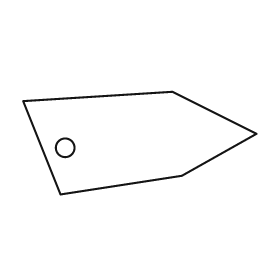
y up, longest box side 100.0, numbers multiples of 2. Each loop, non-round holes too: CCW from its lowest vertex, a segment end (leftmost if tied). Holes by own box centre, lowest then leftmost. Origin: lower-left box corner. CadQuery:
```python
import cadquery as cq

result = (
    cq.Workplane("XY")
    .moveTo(16.0, 0.0)
    .lineTo(68.0, 8.0)
    .lineTo(100.0, 26.0)
    .lineTo(64.0, 44.0)
    .lineTo(0.0, 40.0)
    .close()
    .moveTo(18.0, 20.0)
    .circle(4.0)
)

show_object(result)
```